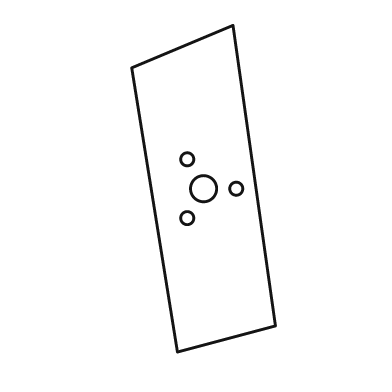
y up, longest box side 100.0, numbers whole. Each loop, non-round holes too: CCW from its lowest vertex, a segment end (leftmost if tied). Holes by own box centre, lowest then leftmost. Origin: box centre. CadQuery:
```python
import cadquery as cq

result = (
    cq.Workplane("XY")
    .moveTo(-8.0, -50.0)
    .lineTo(22.0, -42.0)
    .lineTo(9.0, 50.0)
    .lineTo(-22.0, 37.0)
    .close()
    .moveTo(-5.0, -9.0)
    .circle(2.0)
    .moveTo(0.0, 0.0)
    .circle(4.0)
    .moveTo(10.0, 0.0)
    .circle(2.0)
    .moveTo(-5.0, 9.0)
    .circle(2.0)
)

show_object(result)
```